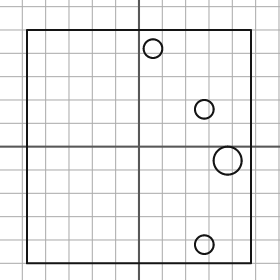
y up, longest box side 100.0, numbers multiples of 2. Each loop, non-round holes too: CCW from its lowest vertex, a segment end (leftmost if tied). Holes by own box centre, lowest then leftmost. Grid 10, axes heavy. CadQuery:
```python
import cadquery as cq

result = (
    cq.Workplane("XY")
    .moveTo(-48.0, -50.0)
    .lineTo(48.0, -50.0)
    .lineTo(48.0, 50.0)
    .lineTo(-48.0, 50.0)
    .close()
    .moveTo(28.0, -42.0)
    .circle(4.0)
    .moveTo(38.0, -6.0)
    .circle(6.0)
    .moveTo(28.0, 16.0)
    .circle(4.0)
    .moveTo(6.0, 42.0)
    .circle(4.0)
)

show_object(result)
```